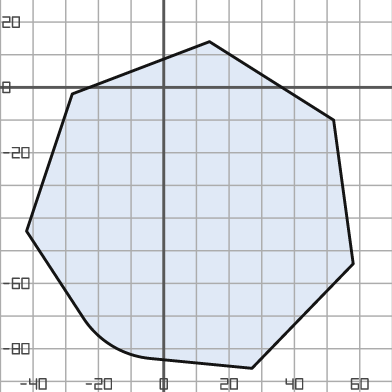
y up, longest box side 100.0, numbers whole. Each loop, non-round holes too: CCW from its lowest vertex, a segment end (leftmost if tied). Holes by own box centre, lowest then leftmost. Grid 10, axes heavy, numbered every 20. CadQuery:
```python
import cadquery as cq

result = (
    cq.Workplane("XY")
    .moveTo(27.0, -86.0)
    .lineTo(58.0, -54.0)
    .lineTo(52.0, -10.0)
    .lineTo(14.0, 14.0)
    .lineTo(-28.0, -2.0)
    .lineTo(-42.0, -44.0)
    .lineTo(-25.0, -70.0)
    .threePointArc((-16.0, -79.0), (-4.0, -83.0))
    .close()
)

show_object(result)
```